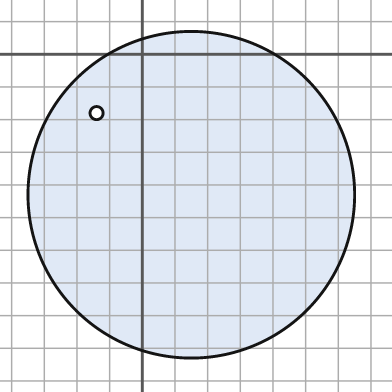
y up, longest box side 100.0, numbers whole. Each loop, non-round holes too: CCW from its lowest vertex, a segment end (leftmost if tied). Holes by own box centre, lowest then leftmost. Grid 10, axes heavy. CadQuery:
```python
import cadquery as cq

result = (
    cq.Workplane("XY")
    .moveTo(15.0, -43.0)
    .circle(50.0)
    .moveTo(-14.0, -18.0)
    .circle(2.0)
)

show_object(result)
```